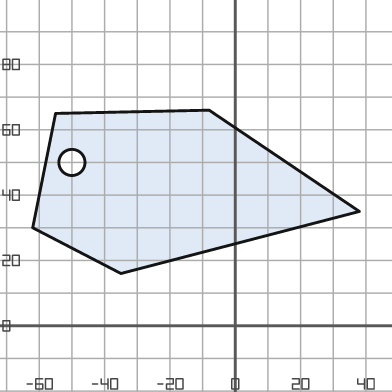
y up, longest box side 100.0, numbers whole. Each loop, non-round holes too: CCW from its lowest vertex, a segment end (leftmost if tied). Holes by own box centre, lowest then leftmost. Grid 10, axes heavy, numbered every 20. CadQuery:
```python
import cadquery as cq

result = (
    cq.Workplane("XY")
    .moveTo(-35.0, 16.0)
    .lineTo(38.0, 35.0)
    .lineTo(-8.0, 66.0)
    .lineTo(-55.0, 65.0)
    .lineTo(-62.0, 30.0)
    .close()
    .moveTo(-50.0, 50.0)
    .circle(4.0)
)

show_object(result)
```